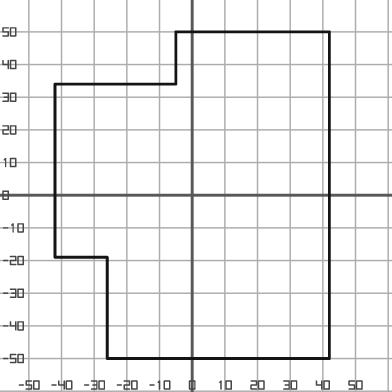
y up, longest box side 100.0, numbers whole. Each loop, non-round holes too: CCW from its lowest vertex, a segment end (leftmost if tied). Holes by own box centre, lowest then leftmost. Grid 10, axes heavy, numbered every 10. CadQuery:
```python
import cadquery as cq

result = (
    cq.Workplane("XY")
    .moveTo(-26.0, -50.0)
    .lineTo(42.0, -50.0)
    .lineTo(42.0, 50.0)
    .lineTo(-5.0, 50.0)
    .lineTo(-5.0, 34.0)
    .lineTo(-42.0, 34.0)
    .lineTo(-42.0, -19.0)
    .lineTo(-26.0, -19.0)
    .close()
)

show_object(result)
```